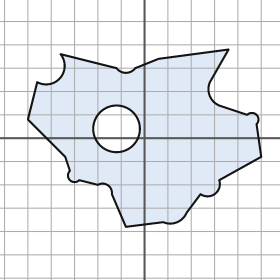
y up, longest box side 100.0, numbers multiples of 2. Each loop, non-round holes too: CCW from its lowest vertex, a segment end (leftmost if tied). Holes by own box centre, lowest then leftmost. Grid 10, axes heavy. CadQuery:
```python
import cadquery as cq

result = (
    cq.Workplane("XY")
    .moveTo(-8.0, -38.0)
    .lineTo(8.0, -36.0)
    .threePointArc((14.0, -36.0), (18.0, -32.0))
    .lineTo(24.0, -24.0)
    .threePointArc((30.0, -24.0), (32.0, -18.0))
    .lineTo(50.0, -8.0)
    .lineTo(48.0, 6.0)
    .threePointArc((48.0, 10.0), (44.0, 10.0))
    .lineTo(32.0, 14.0)
    .threePointArc((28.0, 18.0), (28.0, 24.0))
    .lineTo(36.0, 38.0)
    .lineTo(6.0, 34.0)
    .lineTo(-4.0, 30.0)
    .threePointArc((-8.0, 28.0), (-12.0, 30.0))
    .lineTo(-36.0, 36.0)
    .threePointArc((-36.0, 26.0), (-46.0, 24.0))
    .lineTo(-50.0, 8.0)
    .lineTo(-34.0, -8.0)
    .lineTo(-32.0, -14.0)
    .threePointArc((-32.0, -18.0), (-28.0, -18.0))
    .lineTo(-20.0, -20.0)
    .threePointArc((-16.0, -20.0), (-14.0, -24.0))
    .close()
    .moveTo(-12.0, 4.0)
    .circle(10.0)
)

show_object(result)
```